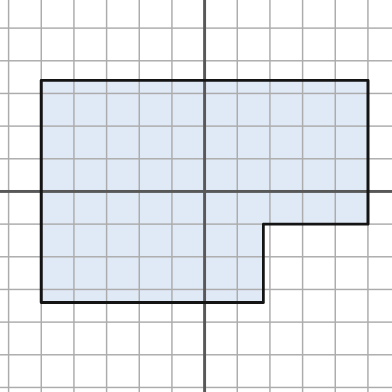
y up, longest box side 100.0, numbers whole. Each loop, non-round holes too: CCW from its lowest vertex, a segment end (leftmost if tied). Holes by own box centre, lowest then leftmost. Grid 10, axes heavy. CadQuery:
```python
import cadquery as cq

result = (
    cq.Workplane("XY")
    .moveTo(-50.0, -34.0)
    .lineTo(18.0, -34.0)
    .lineTo(18.0, -10.0)
    .lineTo(50.0, -10.0)
    .lineTo(50.0, 34.0)
    .lineTo(-50.0, 34.0)
    .close()
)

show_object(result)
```